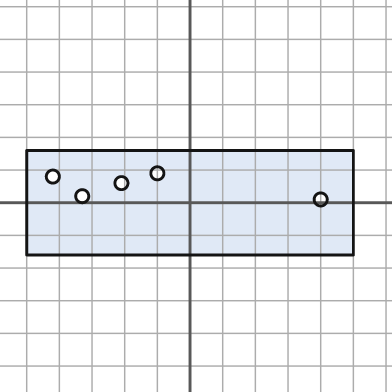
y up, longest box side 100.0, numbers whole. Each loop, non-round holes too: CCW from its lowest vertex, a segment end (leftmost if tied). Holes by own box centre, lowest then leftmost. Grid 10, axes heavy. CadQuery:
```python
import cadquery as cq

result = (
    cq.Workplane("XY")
    .moveTo(-50.0, -16.0)
    .lineTo(50.0, -16.0)
    .lineTo(50.0, 16.0)
    .lineTo(-50.0, 16.0)
    .close()
    .moveTo(40.0, 1.0)
    .circle(2.0)
    .moveTo(-33.0, 2.0)
    .circle(2.0)
    .moveTo(-21.0, 6.0)
    .circle(2.0)
    .moveTo(-42.0, 8.0)
    .circle(2.0)
    .moveTo(-10.0, 9.0)
    .circle(2.0)
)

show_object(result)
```